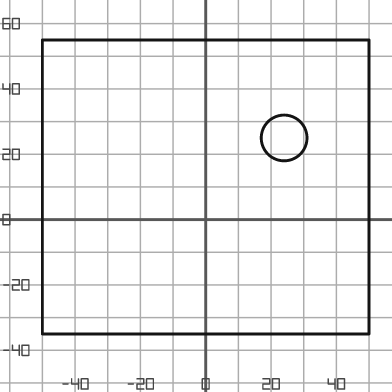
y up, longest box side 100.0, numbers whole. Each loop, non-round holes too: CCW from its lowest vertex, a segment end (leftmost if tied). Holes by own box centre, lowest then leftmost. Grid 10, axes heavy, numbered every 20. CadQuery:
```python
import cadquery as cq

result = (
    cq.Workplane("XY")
    .moveTo(-50.0, -35.0)
    .lineTo(50.0, -35.0)
    .lineTo(50.0, 55.0)
    .lineTo(-50.0, 55.0)
    .close()
    .moveTo(24.0, 25.0)
    .circle(7.0)
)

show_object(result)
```